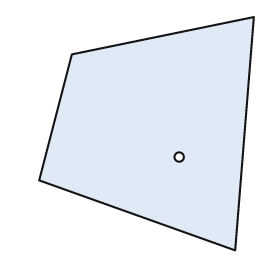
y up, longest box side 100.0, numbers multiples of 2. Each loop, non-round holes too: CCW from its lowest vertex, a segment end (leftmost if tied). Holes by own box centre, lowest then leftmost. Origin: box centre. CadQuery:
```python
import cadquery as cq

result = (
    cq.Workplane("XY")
    .moveTo(38.0, -50.0)
    .lineTo(46.0, 50.0)
    .lineTo(-32.0, 34.0)
    .lineTo(-46.0, -20.0)
    .close()
    .moveTo(14.0, -10.0)
    .circle(2.0)
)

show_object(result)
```